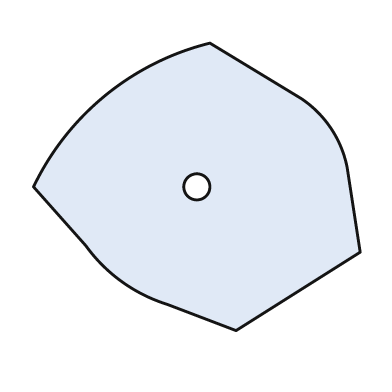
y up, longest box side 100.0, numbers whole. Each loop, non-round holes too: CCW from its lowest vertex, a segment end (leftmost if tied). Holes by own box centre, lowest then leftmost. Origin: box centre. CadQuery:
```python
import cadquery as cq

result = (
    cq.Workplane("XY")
    .moveTo(12.0, -44.0)
    .lineTo(50.0, -20.0)
    .lineTo(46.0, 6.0)
    .threePointArc((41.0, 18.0), (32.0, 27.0))
    .lineTo(4.0, 44.0)
    .threePointArc((-28.0, 28.0), (-50.0, 0.0))
    .lineTo(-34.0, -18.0)
    .threePointArc((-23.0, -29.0), (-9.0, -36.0))
    .close()
    .moveTo(0.0, 0.0)
    .circle(4.0)
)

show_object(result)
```